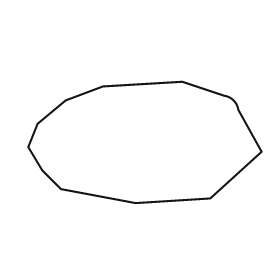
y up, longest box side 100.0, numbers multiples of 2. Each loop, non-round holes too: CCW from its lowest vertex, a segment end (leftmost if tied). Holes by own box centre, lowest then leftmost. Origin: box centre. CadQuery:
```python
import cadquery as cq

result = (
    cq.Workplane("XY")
    .moveTo(-4.0, -26.0)
    .lineTo(28.0, -24.0)
    .lineTo(50.0, -4.0)
    .lineTo(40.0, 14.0)
    .threePointArc((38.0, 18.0), (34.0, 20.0))
    .lineTo(16.0, 26.0)
    .lineTo(-18.0, 24.0)
    .lineTo(-34.0, 18.0)
    .lineTo(-46.0, 8.0)
    .lineTo(-50.0, -2.0)
    .lineTo(-44.0, -12.0)
    .lineTo(-36.0, -20.0)
    .close()
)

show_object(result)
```